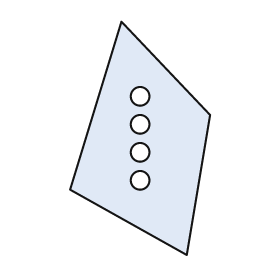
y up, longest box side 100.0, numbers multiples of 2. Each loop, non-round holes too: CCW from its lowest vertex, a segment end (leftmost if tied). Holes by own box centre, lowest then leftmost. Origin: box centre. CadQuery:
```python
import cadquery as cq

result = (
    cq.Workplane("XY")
    .moveTo(20.0, -50.0)
    .lineTo(30.0, 10.0)
    .lineTo(-8.0, 50.0)
    .lineTo(-30.0, -22.0)
    .close()
    .moveTo(0.0, -18.0)
    .circle(4.0)
    .moveTo(0.0, -6.0)
    .circle(4.0)
    .moveTo(0.0, 6.0)
    .circle(4.0)
    .moveTo(0.0, 18.0)
    .circle(4.0)
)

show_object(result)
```